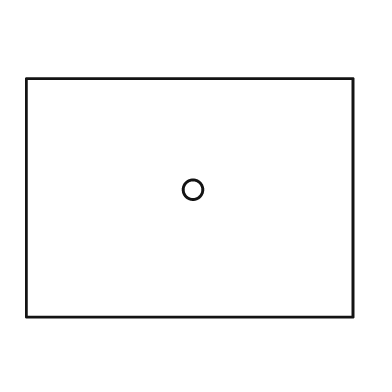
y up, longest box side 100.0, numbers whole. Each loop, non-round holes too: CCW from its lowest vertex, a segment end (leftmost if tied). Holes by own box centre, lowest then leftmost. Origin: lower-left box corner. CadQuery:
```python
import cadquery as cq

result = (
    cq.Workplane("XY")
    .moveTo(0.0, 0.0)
    .lineTo(100.0, 0.0)
    .lineTo(100.0, 73.0)
    .lineTo(0.0, 73.0)
    .close()
    .moveTo(51.0, 39.0)
    .circle(3.0)
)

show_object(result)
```